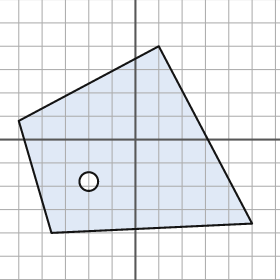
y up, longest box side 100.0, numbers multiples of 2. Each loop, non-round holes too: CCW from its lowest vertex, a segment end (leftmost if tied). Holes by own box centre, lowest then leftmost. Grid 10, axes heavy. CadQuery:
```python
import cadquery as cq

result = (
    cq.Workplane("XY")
    .moveTo(-36.0, -40.0)
    .lineTo(50.0, -36.0)
    .lineTo(10.0, 40.0)
    .lineTo(-50.0, 8.0)
    .close()
    .moveTo(-20.0, -18.0)
    .circle(4.0)
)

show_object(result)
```